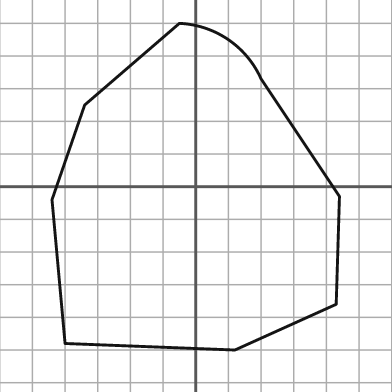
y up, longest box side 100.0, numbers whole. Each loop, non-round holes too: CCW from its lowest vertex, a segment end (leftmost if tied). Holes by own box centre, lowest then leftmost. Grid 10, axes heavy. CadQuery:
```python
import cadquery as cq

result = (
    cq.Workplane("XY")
    .moveTo(12.0, -50.0)
    .lineTo(43.0, -36.0)
    .lineTo(44.0, -3.0)
    .lineTo(20.0, 33.0)
    .threePointArc((10.0, 45.0), (-5.0, 50.0))
    .lineTo(-34.0, 25.0)
    .lineTo(-44.0, -4.0)
    .lineTo(-40.0, -48.0)
    .close()
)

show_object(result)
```